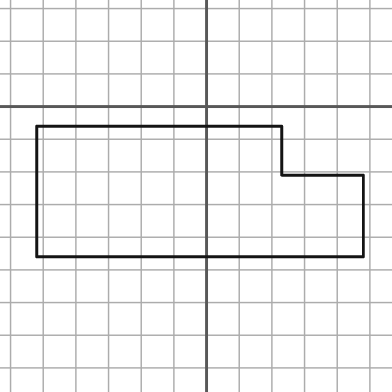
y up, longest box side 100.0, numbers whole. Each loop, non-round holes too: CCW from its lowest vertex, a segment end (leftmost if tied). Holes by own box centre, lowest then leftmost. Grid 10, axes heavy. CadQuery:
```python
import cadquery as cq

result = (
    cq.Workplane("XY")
    .moveTo(-52.0, -46.0)
    .lineTo(48.0, -46.0)
    .lineTo(48.0, -21.0)
    .lineTo(23.0, -21.0)
    .lineTo(23.0, -6.0)
    .lineTo(-52.0, -6.0)
    .close()
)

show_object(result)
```